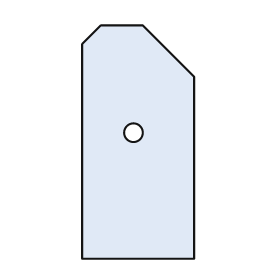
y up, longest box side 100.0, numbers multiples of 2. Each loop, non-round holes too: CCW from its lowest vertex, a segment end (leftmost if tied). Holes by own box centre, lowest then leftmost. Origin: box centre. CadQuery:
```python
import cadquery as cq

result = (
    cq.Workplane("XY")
    .moveTo(-24.0, -50.0)
    .lineTo(24.0, -50.0)
    .lineTo(24.0, 28.0)
    .lineTo(2.0, 50.0)
    .lineTo(-16.0, 50.0)
    .lineTo(-24.0, 42.0)
    .close()
    .moveTo(-2.0, 4.0)
    .circle(4.0)
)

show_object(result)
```